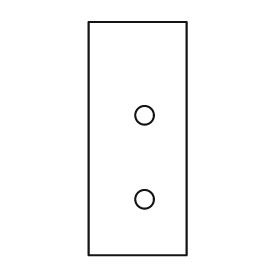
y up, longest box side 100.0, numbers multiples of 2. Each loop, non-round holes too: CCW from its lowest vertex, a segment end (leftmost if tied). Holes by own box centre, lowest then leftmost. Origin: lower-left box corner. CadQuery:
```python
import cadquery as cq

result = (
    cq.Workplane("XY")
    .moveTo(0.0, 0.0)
    .lineTo(42.0, 0.0)
    .lineTo(42.0, 100.0)
    .lineTo(0.0, 100.0)
    .close()
    .moveTo(24.0, 24.0)
    .circle(4.0)
    .moveTo(24.0, 60.0)
    .circle(4.0)
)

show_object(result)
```